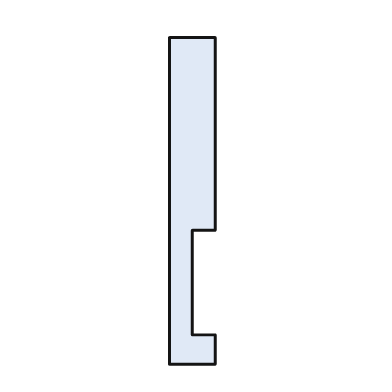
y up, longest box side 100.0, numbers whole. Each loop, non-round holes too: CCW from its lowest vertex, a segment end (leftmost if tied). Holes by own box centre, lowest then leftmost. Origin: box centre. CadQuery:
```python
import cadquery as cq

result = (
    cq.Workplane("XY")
    .moveTo(-7.0, -50.0)
    .lineTo(7.0, -50.0)
    .lineTo(7.0, -41.0)
    .lineTo(0.0, -41.0)
    .lineTo(0.0, -9.0)
    .lineTo(7.0, -9.0)
    .lineTo(7.0, 50.0)
    .lineTo(-7.0, 50.0)
    .close()
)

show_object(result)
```